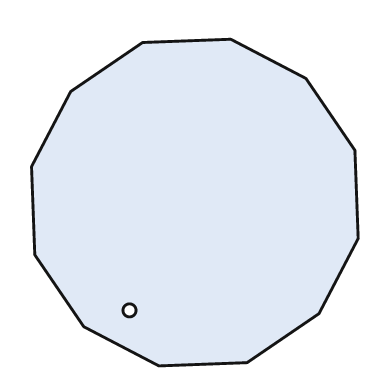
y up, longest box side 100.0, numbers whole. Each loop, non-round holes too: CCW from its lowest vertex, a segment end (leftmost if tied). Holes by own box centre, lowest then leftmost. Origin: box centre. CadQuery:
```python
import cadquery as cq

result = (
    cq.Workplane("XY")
    .moveTo(-11.0, -50.0)
    .lineTo(16.0, -49.0)
    .lineTo(38.0, -34.0)
    .lineTo(50.0, -11.0)
    .lineTo(49.0, 16.0)
    .lineTo(34.0, 38.0)
    .lineTo(11.0, 50.0)
    .lineTo(-16.0, 49.0)
    .lineTo(-38.0, 34.0)
    .lineTo(-50.0, 11.0)
    .lineTo(-49.0, -16.0)
    .lineTo(-34.0, -38.0)
    .close()
    .moveTo(-20.0, -33.0)
    .circle(2.0)
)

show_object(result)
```